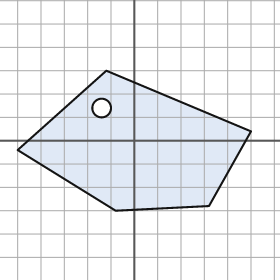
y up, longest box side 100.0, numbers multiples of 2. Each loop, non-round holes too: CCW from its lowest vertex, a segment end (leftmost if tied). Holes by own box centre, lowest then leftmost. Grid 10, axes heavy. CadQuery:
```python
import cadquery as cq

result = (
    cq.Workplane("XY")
    .moveTo(-8.0, -30.0)
    .lineTo(32.0, -28.0)
    .lineTo(50.0, 4.0)
    .lineTo(-12.0, 30.0)
    .lineTo(-50.0, -4.0)
    .close()
    .moveTo(-14.0, 14.0)
    .circle(4.0)
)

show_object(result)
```